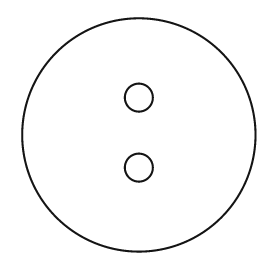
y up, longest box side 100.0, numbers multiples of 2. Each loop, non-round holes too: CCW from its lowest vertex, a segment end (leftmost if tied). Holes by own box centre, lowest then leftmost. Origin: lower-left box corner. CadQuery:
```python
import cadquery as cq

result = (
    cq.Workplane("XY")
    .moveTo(50.0, 50.0)
    .circle(50.0)
    .moveTo(50.0, 36.0)
    .circle(6.0)
    .moveTo(50.0, 66.0)
    .circle(6.0)
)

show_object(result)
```